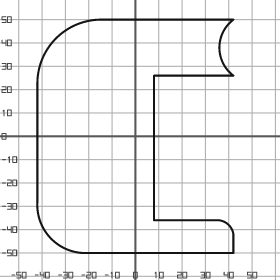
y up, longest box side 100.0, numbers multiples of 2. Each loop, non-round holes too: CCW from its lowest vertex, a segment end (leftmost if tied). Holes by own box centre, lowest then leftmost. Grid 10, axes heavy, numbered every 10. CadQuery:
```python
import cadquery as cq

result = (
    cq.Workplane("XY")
    .moveTo(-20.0, -50.0)
    .lineTo(42.0, -50.0)
    .lineTo(42.0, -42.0)
    .threePointArc((40.0, -38.0), (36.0, -36.0))
    .lineTo(8.0, -36.0)
    .lineTo(8.0, 26.0)
    .lineTo(42.0, 26.0)
    .threePointArc((36.0, 38.0), (42.0, 50.0))
    .lineTo(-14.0, 50.0)
    .threePointArc((-34.0, 42.0), (-42.0, 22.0))
    .lineTo(-42.0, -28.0)
    .threePointArc((-36.0, -44.0), (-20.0, -50.0))
    .close()
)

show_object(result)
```